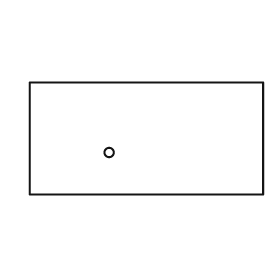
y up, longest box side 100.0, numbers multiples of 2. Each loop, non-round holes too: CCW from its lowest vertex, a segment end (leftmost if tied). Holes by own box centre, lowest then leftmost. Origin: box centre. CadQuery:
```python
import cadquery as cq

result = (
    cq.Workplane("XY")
    .moveTo(-50.0, -24.0)
    .lineTo(50.0, -24.0)
    .lineTo(50.0, 24.0)
    .lineTo(-50.0, 24.0)
    .close()
    .moveTo(-16.0, -6.0)
    .circle(2.0)
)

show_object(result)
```